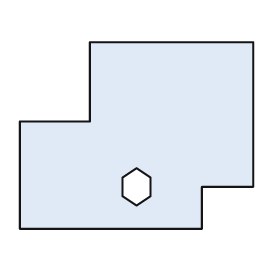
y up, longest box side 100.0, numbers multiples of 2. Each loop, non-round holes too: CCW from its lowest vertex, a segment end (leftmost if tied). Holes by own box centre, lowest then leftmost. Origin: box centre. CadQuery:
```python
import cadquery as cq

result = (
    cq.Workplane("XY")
    .moveTo(-50.0, -40.0)
    .lineTo(28.0, -40.0)
    .lineTo(28.0, -22.0)
    .lineTo(50.0, -22.0)
    .lineTo(50.0, 40.0)
    .lineTo(-20.0, 40.0)
    .lineTo(-20.0, 6.0)
    .lineTo(-50.0, 6.0)
    .close()
    .moveTo(0.0, -30.0)
    .lineTo(6.0, -26.0)
    .lineTo(6.0, -18.0)
    .lineTo(0.0, -14.0)
    .lineTo(-6.0, -18.0)
    .lineTo(-6.0, -26.0)
    .close()
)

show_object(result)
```